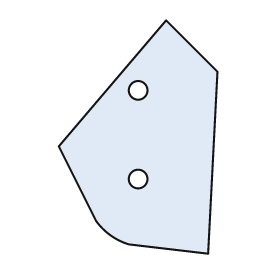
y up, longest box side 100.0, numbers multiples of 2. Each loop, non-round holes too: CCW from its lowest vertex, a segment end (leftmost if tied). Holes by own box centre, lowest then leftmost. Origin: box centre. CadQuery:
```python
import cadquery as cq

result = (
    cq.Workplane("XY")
    .moveTo(30.0, -50.0)
    .lineTo(34.0, 28.0)
    .lineTo(12.0, 50.0)
    .lineTo(-34.0, -4.0)
    .lineTo(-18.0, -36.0)
    .threePointArc((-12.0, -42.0), (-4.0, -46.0))
    .close()
    .moveTo(0.0, -18.0)
    .circle(4.0)
    .moveTo(0.0, 20.0)
    .circle(4.0)
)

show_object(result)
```